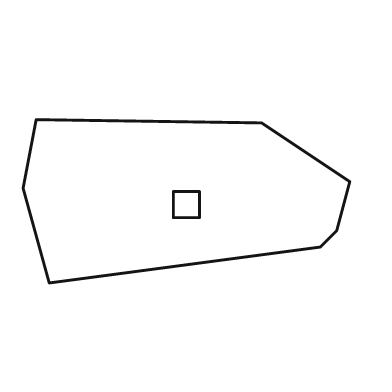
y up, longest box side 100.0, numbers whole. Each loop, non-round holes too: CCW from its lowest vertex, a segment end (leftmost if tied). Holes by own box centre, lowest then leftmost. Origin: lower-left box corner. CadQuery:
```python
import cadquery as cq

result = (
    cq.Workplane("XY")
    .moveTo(8.0, 0.0)
    .lineTo(91.0, 11.0)
    .lineTo(96.0, 16.0)
    .lineTo(100.0, 31.0)
    .lineTo(73.0, 49.0)
    .lineTo(4.0, 50.0)
    .lineTo(0.0, 29.0)
    .close()
    .moveTo(46.0, 20.0)
    .lineTo(54.0, 20.0)
    .lineTo(54.0, 28.0)
    .lineTo(46.0, 28.0)
    .close()
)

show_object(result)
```